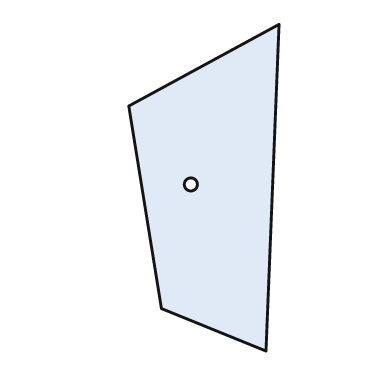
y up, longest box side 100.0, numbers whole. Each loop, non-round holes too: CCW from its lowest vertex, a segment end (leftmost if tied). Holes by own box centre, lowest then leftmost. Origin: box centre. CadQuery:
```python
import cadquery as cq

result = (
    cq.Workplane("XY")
    .moveTo(19.0, -50.0)
    .lineTo(23.0, 50.0)
    .lineTo(-23.0, 25.0)
    .lineTo(-13.0, -37.0)
    .close()
    .moveTo(-4.0, 1.0)
    .circle(2.0)
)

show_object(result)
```